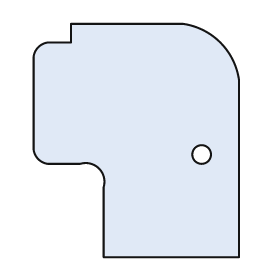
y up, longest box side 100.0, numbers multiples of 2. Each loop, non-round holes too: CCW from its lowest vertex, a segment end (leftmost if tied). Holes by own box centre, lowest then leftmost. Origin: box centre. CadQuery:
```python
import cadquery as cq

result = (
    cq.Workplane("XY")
    .moveTo(-14.0, -50.0)
    .lineTo(44.0, -50.0)
    .lineTo(44.0, 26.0)
    .threePointArc((36.0, 42.0), (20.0, 50.0))
    .lineTo(-28.0, 50.0)
    .lineTo(-28.0, 42.0)
    .lineTo(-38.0, 42.0)
    .threePointArc((-42.0, 40.0), (-44.0, 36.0))
    .lineTo(-44.0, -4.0)
    .threePointArc((-42.0, -8.0), (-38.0, -10.0))
    .lineTo(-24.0, -10.0)
    .threePointArc((-16.0, -12.0), (-14.0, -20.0))
    .close()
    .moveTo(28.0, -6.0)
    .circle(4.0)
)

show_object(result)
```